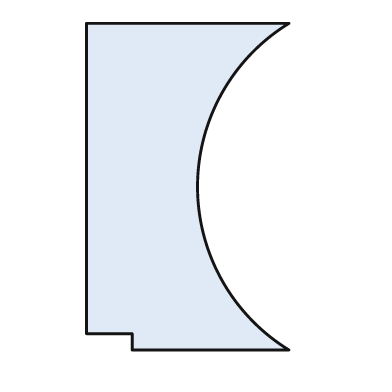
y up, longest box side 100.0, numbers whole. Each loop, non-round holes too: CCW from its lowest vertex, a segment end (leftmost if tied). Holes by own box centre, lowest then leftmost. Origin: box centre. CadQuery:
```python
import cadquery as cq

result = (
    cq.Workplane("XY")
    .moveTo(-17.0, -50.0)
    .lineTo(31.0, -50.0)
    .threePointArc((3.0, 0.0), (31.0, 50.0))
    .lineTo(-31.0, 50.0)
    .lineTo(-31.0, -45.0)
    .lineTo(-17.0, -45.0)
    .close()
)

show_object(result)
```